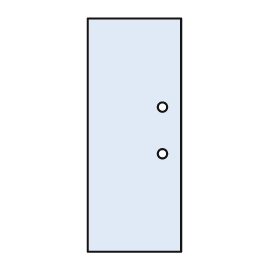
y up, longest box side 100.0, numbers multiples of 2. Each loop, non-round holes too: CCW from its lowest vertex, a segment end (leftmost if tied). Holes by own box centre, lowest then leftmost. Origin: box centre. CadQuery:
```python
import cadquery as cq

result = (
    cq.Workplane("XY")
    .moveTo(-20.0, -50.0)
    .lineTo(20.0, -50.0)
    .lineTo(20.0, 50.0)
    .lineTo(-20.0, 50.0)
    .close()
    .moveTo(12.0, -8.0)
    .circle(2.0)
    .moveTo(12.0, 12.0)
    .circle(2.0)
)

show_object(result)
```